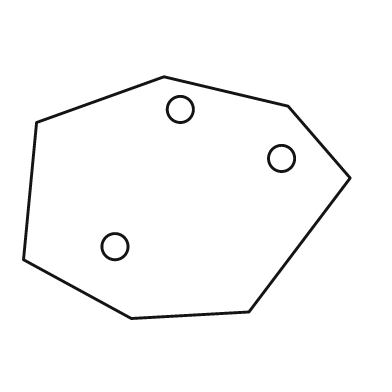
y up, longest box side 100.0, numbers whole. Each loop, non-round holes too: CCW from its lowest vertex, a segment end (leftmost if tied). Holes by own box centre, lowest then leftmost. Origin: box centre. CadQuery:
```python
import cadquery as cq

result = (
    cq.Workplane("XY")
    .moveTo(-17.0, -37.0)
    .lineTo(19.0, -35.0)
    .lineTo(50.0, 6.0)
    .lineTo(31.0, 28.0)
    .lineTo(-7.0, 37.0)
    .lineTo(-46.0, 23.0)
    .lineTo(-50.0, -19.0)
    .close()
    .moveTo(-22.0, -15.0)
    .circle(4.0)
    .moveTo(29.0, 12.0)
    .circle(4.0)
    .moveTo(-2.0, 27.0)
    .circle(4.0)
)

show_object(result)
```